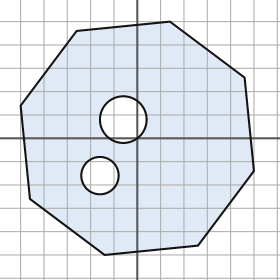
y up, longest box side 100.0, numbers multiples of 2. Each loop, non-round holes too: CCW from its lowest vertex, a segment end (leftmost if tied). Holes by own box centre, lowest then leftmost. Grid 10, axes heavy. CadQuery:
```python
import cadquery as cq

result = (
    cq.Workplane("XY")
    .moveTo(-14.0, -50.0)
    .lineTo(26.0, -46.0)
    .lineTo(50.0, -14.0)
    .lineTo(46.0, 26.0)
    .lineTo(14.0, 50.0)
    .lineTo(-26.0, 46.0)
    .lineTo(-50.0, 14.0)
    .lineTo(-46.0, -26.0)
    .close()
    .moveTo(-16.0, -16.0)
    .circle(8.0)
    .moveTo(-6.0, 8.0)
    .circle(10.0)
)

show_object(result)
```